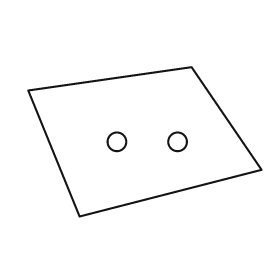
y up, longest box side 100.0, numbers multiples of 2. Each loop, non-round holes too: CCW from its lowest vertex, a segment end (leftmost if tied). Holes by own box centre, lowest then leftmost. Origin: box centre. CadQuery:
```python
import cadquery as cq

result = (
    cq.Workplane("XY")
    .moveTo(-28.0, -32.0)
    .lineTo(50.0, -12.0)
    .lineTo(20.0, 32.0)
    .lineTo(-50.0, 22.0)
    .close()
    .moveTo(-12.0, 0.0)
    .circle(4.0)
    .moveTo(14.0, 0.0)
    .circle(4.0)
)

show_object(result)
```